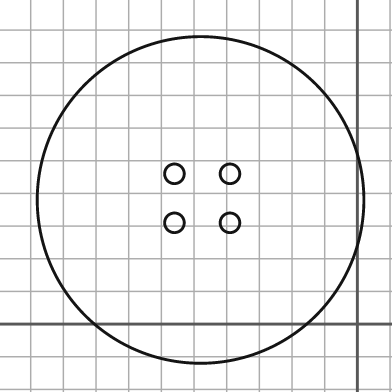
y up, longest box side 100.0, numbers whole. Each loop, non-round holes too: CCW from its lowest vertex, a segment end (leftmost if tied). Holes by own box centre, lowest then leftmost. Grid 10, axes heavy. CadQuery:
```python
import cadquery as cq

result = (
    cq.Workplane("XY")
    .moveTo(-48.0, 38.0)
    .circle(50.0)
    .moveTo(-56.0, 31.0)
    .circle(3.0)
    .moveTo(-39.0, 31.0)
    .circle(3.0)
    .moveTo(-56.0, 46.0)
    .circle(3.0)
    .moveTo(-39.0, 46.0)
    .circle(3.0)
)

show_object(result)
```